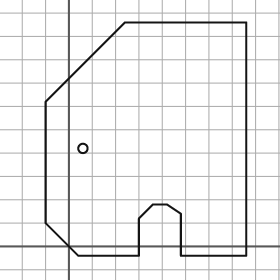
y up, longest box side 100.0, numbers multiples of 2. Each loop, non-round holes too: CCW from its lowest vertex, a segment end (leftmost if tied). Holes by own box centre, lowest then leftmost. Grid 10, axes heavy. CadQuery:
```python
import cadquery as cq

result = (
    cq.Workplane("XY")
    .moveTo(4.0, -4.0)
    .lineTo(30.0, -4.0)
    .lineTo(30.0, 12.0)
    .lineTo(36.0, 18.0)
    .lineTo(42.0, 18.0)
    .lineTo(48.0, 14.0)
    .lineTo(48.0, -4.0)
    .lineTo(76.0, -4.0)
    .lineTo(76.0, 96.0)
    .lineTo(24.0, 96.0)
    .lineTo(-10.0, 62.0)
    .lineTo(-10.0, 10.0)
    .close()
    .moveTo(6.0, 42.0)
    .circle(2.0)
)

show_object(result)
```